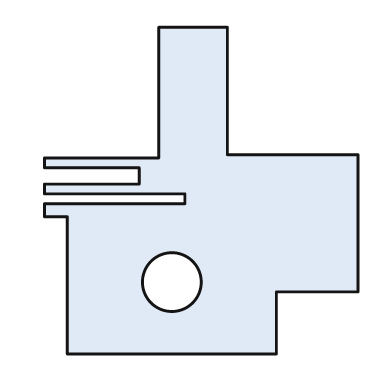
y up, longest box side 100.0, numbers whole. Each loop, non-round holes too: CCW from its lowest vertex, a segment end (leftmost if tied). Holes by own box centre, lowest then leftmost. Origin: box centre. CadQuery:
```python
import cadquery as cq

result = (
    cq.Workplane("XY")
    .moveTo(-41.0, -50.0)
    .lineTo(23.0, -50.0)
    .lineTo(23.0, -31.0)
    .lineTo(48.0, -31.0)
    .lineTo(48.0, 11.0)
    .lineTo(8.0, 11.0)
    .lineTo(8.0, 50.0)
    .lineTo(-13.0, 50.0)
    .lineTo(-13.0, 10.0)
    .lineTo(-48.0, 10.0)
    .lineTo(-48.0, 7.0)
    .lineTo(-19.0, 7.0)
    .lineTo(-19.0, 2.0)
    .lineTo(-48.0, 2.0)
    .lineTo(-48.0, -1.0)
    .lineTo(-5.0, -1.0)
    .lineTo(-5.0, -4.0)
    .lineTo(-48.0, -4.0)
    .lineTo(-48.0, -8.0)
    .lineTo(-41.0, -8.0)
    .close()
    .moveTo(-9.0, -28.0)
    .circle(9.0)
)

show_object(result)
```